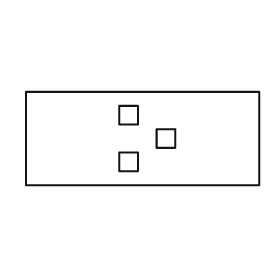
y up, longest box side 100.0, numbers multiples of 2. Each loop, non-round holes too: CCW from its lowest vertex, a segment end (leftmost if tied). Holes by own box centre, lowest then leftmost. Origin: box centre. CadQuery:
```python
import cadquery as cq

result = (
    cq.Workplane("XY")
    .moveTo(-50.0, -20.0)
    .lineTo(50.0, -20.0)
    .lineTo(50.0, 20.0)
    .lineTo(-50.0, 20.0)
    .close()
    .moveTo(-10.0, -14.0)
    .lineTo(-2.0, -14.0)
    .lineTo(-2.0, -6.0)
    .lineTo(-10.0, -6.0)
    .close()
    .moveTo(6.0, -4.0)
    .lineTo(14.0, -4.0)
    .lineTo(14.0, 4.0)
    .lineTo(6.0, 4.0)
    .close()
    .moveTo(-10.0, 6.0)
    .lineTo(-2.0, 6.0)
    .lineTo(-2.0, 14.0)
    .lineTo(-10.0, 14.0)
    .close()
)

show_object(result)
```